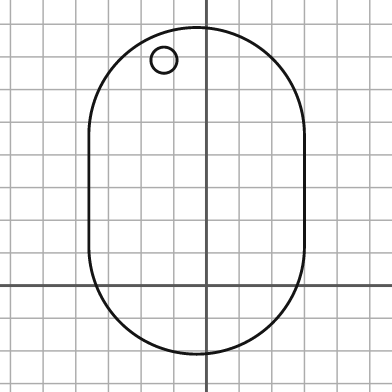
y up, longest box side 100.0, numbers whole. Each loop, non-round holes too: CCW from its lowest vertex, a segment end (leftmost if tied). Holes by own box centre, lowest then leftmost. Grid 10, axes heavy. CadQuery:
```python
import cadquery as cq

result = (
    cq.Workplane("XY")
    .moveTo(-36.0, 12.0)
    .threePointArc((-3.0, -21.0), (30.0, 12.0))
    .lineTo(30.0, 46.0)
    .threePointArc((-3.0, 79.0), (-36.0, 46.0))
    .close()
    .moveTo(-13.0, 69.0)
    .circle(4.0)
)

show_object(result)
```